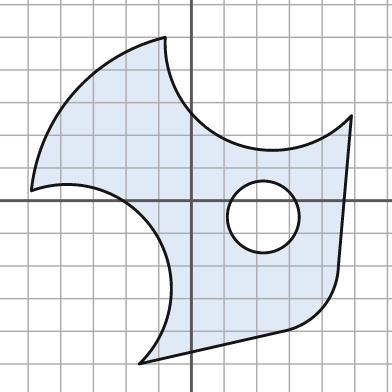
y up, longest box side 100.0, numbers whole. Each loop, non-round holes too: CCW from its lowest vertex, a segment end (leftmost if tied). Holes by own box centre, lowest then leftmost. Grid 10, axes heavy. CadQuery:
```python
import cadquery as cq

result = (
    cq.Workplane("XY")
    .moveTo(-16.0, -50.0)
    .lineTo(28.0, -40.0)
    .threePointArc((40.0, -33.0), (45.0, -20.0))
    .lineTo(49.0, 26.0)
    .threePointArc((12.0, 18.0), (-8.0, 50.0))
    .threePointArc((-36.0, 33.0), (-49.0, 3.0))
    .threePointArc((-11.0, -10.0), (-16.0, -50.0))
    .close()
    .moveTo(22.0, -5.0)
    .circle(11.0)
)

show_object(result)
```